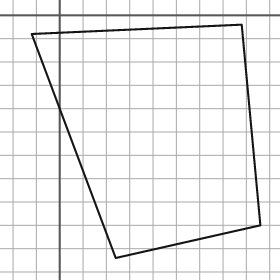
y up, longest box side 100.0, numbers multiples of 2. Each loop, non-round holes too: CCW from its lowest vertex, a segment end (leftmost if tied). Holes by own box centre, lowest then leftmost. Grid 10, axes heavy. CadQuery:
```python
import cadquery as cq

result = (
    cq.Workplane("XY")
    .moveTo(24.0, -104.0)
    .lineTo(86.0, -90.0)
    .lineTo(78.0, -4.0)
    .lineTo(-12.0, -8.0)
    .close()
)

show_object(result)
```